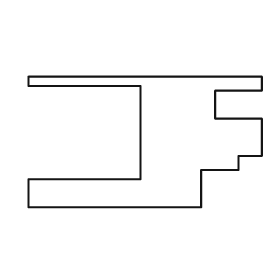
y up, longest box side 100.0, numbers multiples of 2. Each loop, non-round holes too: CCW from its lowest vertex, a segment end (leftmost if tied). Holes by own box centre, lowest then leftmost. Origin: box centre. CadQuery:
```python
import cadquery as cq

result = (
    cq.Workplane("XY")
    .moveTo(-50.0, -28.0)
    .lineTo(24.0, -28.0)
    .lineTo(24.0, -12.0)
    .lineTo(40.0, -12.0)
    .lineTo(40.0, -6.0)
    .lineTo(50.0, -6.0)
    .lineTo(50.0, 10.0)
    .lineTo(30.0, 10.0)
    .lineTo(30.0, 22.0)
    .lineTo(50.0, 22.0)
    .lineTo(50.0, 28.0)
    .lineTo(-50.0, 28.0)
    .lineTo(-50.0, 24.0)
    .lineTo(-2.0, 24.0)
    .lineTo(-2.0, -16.0)
    .lineTo(-50.0, -16.0)
    .close()
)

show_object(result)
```